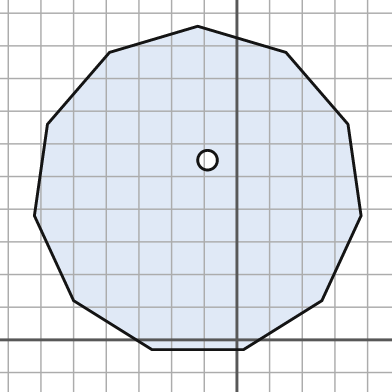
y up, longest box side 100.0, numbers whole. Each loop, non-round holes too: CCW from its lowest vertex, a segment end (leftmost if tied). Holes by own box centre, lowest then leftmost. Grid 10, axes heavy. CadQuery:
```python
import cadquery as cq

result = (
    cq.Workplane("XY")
    .moveTo(-26.0, -3.0)
    .lineTo(2.0, -3.0)
    .lineTo(26.0, 12.0)
    .lineTo(38.0, 38.0)
    .lineTo(34.0, 66.0)
    .lineTo(15.0, 88.0)
    .lineTo(-12.0, 96.0)
    .lineTo(-39.0, 88.0)
    .lineTo(-58.0, 66.0)
    .lineTo(-62.0, 38.0)
    .lineTo(-50.0, 12.0)
    .close()
    .moveTo(-9.0, 55.0)
    .circle(3.0)
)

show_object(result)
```